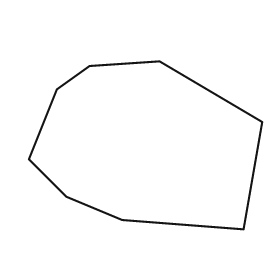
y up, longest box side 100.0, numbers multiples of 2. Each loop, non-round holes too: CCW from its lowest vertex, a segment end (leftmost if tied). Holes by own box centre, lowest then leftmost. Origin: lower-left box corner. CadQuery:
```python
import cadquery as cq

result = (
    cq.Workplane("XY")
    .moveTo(92.0, 0.0)
    .lineTo(100.0, 46.0)
    .lineTo(56.0, 72.0)
    .lineTo(26.0, 70.0)
    .lineTo(12.0, 60.0)
    .lineTo(0.0, 30.0)
    .lineTo(16.0, 14.0)
    .lineTo(40.0, 4.0)
    .close()
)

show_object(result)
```